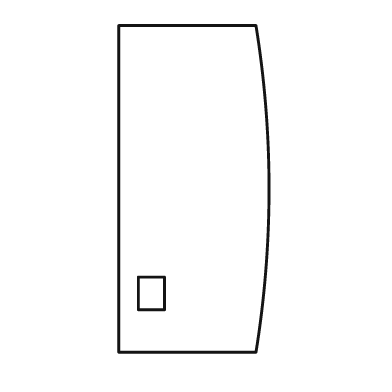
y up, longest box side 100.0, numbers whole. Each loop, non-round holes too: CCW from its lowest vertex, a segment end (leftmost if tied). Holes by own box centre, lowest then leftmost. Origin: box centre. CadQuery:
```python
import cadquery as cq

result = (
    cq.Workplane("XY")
    .moveTo(-23.0, -50.0)
    .lineTo(19.0, -50.0)
    .threePointArc((23.0, 0.0), (19.0, 50.0))
    .lineTo(-23.0, 50.0)
    .close()
    .moveTo(-17.0, -37.0)
    .lineTo(-9.0, -37.0)
    .lineTo(-9.0, -27.0)
    .lineTo(-17.0, -27.0)
    .close()
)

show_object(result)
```